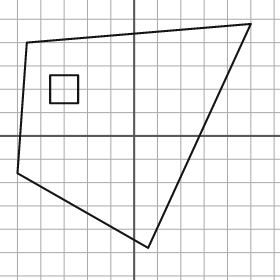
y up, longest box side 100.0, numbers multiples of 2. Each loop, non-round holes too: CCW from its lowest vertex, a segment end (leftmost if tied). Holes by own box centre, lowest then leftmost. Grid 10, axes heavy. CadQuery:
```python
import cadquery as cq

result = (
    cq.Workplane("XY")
    .moveTo(6.0, -48.0)
    .lineTo(50.0, 48.0)
    .lineTo(-46.0, 40.0)
    .lineTo(-50.0, -16.0)
    .close()
    .moveTo(-36.0, 14.0)
    .lineTo(-24.0, 14.0)
    .lineTo(-24.0, 26.0)
    .lineTo(-36.0, 26.0)
    .close()
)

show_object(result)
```